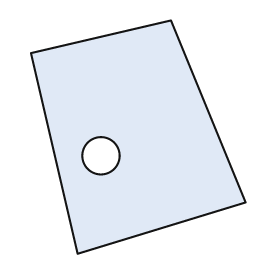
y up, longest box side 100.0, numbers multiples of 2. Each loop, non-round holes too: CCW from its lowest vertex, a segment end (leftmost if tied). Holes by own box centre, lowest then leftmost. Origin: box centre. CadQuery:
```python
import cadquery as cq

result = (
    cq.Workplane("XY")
    .moveTo(-26.0, -50.0)
    .lineTo(46.0, -28.0)
    .lineTo(14.0, 50.0)
    .lineTo(-46.0, 36.0)
    .close()
    .moveTo(-16.0, -8.0)
    .circle(8.0)
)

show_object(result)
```